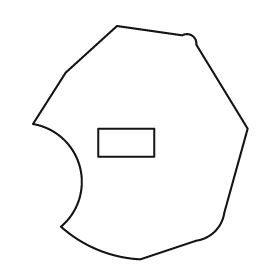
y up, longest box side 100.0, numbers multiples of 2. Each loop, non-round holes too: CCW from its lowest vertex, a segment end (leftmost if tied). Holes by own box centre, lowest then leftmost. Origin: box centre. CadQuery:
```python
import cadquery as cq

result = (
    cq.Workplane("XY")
    .moveTo(0.0, -50.0)
    .lineTo(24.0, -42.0)
    .threePointArc((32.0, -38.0), (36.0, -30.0))
    .lineTo(46.0, 6.0)
    .lineTo(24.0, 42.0)
    .threePointArc((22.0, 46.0), (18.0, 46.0))
    .lineTo(-10.0, 50.0)
    .lineTo(-32.0, 30.0)
    .lineTo(-46.0, 8.0)
    .threePointArc((-26.0, -10.0), (-34.0, -36.0))
    .threePointArc((-18.0, -46.0), (0.0, -50.0))
    .close()
    .moveTo(-18.0, -6.0)
    .lineTo(6.0, -6.0)
    .lineTo(6.0, 6.0)
    .lineTo(-18.0, 6.0)
    .close()
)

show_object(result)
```